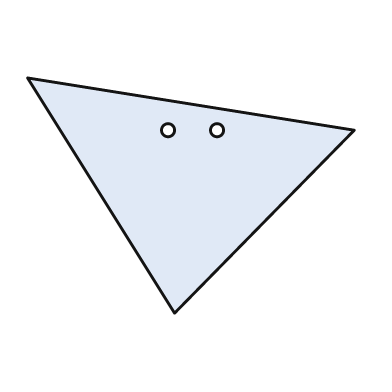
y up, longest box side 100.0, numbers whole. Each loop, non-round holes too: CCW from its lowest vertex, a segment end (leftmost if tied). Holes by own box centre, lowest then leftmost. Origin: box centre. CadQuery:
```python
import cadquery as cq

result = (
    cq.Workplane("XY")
    .moveTo(-5.0, -36.0)
    .lineTo(50.0, 20.0)
    .lineTo(-50.0, 36.0)
    .close()
    .moveTo(-7.0, 20.0)
    .circle(2.0)
    .moveTo(8.0, 20.0)
    .circle(2.0)
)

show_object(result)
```